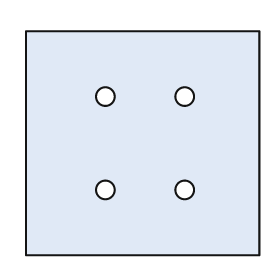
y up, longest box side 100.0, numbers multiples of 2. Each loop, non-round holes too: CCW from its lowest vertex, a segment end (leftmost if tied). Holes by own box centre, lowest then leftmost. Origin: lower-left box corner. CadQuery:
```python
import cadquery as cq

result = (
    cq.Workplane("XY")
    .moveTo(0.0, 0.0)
    .lineTo(100.0, 0.0)
    .lineTo(100.0, 96.0)
    .lineTo(0.0, 96.0)
    .close()
    .moveTo(34.0, 28.0)
    .circle(4.0)
    .moveTo(68.0, 28.0)
    .circle(4.0)
    .moveTo(34.0, 68.0)
    .circle(4.0)
    .moveTo(68.0, 68.0)
    .circle(4.0)
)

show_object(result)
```